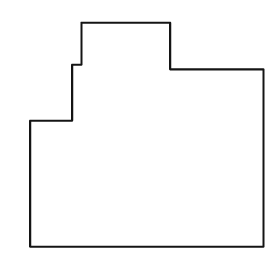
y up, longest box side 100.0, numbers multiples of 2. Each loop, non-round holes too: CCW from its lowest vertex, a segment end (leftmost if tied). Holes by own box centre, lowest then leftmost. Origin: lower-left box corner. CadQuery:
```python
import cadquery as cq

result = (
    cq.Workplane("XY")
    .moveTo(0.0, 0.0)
    .lineTo(100.0, 0.0)
    .lineTo(100.0, 76.0)
    .lineTo(60.0, 76.0)
    .lineTo(60.0, 96.0)
    .lineTo(22.0, 96.0)
    .lineTo(22.0, 78.0)
    .lineTo(18.0, 78.0)
    .lineTo(18.0, 54.0)
    .lineTo(0.0, 54.0)
    .close()
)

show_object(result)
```